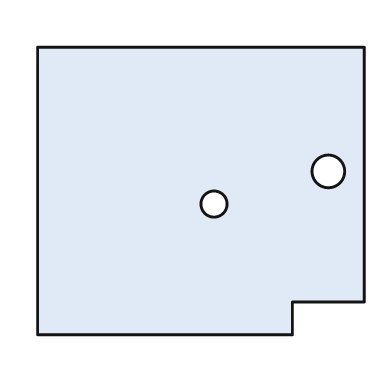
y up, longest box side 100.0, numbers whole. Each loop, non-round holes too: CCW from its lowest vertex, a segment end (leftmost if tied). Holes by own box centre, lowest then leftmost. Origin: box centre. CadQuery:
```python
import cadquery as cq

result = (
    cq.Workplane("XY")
    .moveTo(-50.0, -44.0)
    .lineTo(28.0, -44.0)
    .lineTo(28.0, -34.0)
    .lineTo(50.0, -34.0)
    .lineTo(50.0, 44.0)
    .lineTo(-50.0, 44.0)
    .close()
    .moveTo(4.0, -4.0)
    .circle(4.0)
    .moveTo(39.0, 6.0)
    .circle(5.0)
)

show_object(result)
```